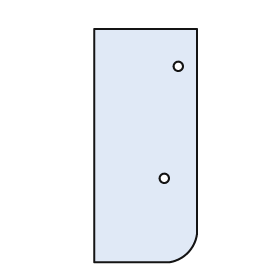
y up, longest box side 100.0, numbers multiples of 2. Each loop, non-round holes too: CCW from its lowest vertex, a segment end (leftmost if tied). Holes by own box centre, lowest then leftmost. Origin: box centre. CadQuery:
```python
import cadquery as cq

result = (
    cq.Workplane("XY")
    .moveTo(-22.0, -50.0)
    .lineTo(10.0, -50.0)
    .threePointArc((18.0, -46.0), (22.0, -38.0))
    .lineTo(22.0, 50.0)
    .lineTo(-22.0, 50.0)
    .close()
    .moveTo(8.0, -14.0)
    .circle(2.0)
    .moveTo(14.0, 34.0)
    .circle(2.0)
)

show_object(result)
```